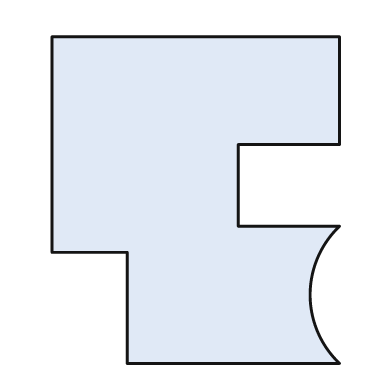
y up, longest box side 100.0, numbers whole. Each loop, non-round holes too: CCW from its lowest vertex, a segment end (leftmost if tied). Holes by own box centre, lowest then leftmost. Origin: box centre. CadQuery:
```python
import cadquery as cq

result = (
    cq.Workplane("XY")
    .moveTo(-21.0, -50.0)
    .lineTo(44.0, -50.0)
    .threePointArc((35.0, -29.0), (44.0, -8.0))
    .lineTo(13.0, -8.0)
    .lineTo(13.0, 17.0)
    .lineTo(44.0, 17.0)
    .lineTo(44.0, 50.0)
    .lineTo(-44.0, 50.0)
    .lineTo(-44.0, -16.0)
    .lineTo(-21.0, -16.0)
    .close()
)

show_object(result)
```